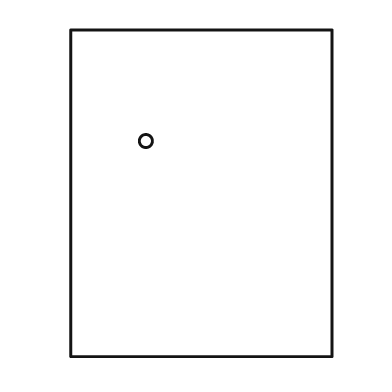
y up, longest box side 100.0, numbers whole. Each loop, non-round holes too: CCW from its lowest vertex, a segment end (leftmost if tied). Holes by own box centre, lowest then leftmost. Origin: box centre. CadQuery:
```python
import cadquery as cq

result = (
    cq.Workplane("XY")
    .moveTo(-40.0, -50.0)
    .lineTo(40.0, -50.0)
    .lineTo(40.0, 50.0)
    .lineTo(-40.0, 50.0)
    .close()
    .moveTo(-17.0, 16.0)
    .circle(2.0)
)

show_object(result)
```